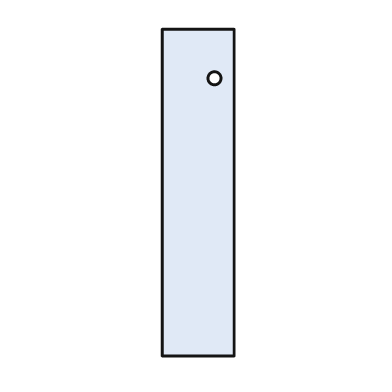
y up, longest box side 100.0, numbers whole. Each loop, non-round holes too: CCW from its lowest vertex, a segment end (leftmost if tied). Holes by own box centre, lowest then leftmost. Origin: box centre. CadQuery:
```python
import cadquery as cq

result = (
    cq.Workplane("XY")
    .moveTo(-11.0, -50.0)
    .lineTo(11.0, -50.0)
    .lineTo(11.0, 50.0)
    .lineTo(-11.0, 50.0)
    .close()
    .moveTo(5.0, 35.0)
    .circle(2.0)
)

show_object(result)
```